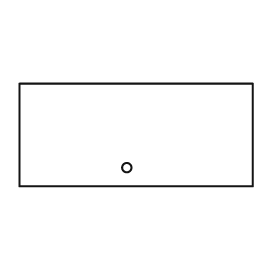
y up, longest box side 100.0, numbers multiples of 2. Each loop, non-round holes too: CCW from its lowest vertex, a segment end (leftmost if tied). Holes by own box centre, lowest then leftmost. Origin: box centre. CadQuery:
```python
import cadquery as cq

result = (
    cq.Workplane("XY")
    .moveTo(-50.0, -22.0)
    .lineTo(50.0, -22.0)
    .lineTo(50.0, 22.0)
    .lineTo(-50.0, 22.0)
    .close()
    .moveTo(-4.0, -14.0)
    .circle(2.0)
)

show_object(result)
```